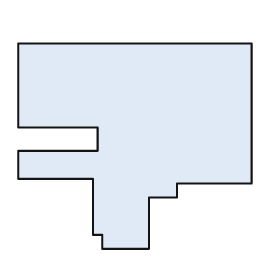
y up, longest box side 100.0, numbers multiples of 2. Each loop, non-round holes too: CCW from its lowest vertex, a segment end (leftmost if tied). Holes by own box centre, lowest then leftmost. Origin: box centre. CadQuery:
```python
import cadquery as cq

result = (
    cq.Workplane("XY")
    .moveTo(-14.0, -44.0)
    .lineTo(6.0, -44.0)
    .lineTo(6.0, -22.0)
    .lineTo(18.0, -22.0)
    .lineTo(18.0, -16.0)
    .lineTo(50.0, -16.0)
    .lineTo(50.0, 44.0)
    .lineTo(-50.0, 44.0)
    .lineTo(-50.0, 8.0)
    .lineTo(-16.0, 8.0)
    .lineTo(-16.0, -2.0)
    .lineTo(-50.0, -2.0)
    .lineTo(-50.0, -14.0)
    .lineTo(-18.0, -14.0)
    .lineTo(-18.0, -38.0)
    .lineTo(-14.0, -38.0)
    .close()
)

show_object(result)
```